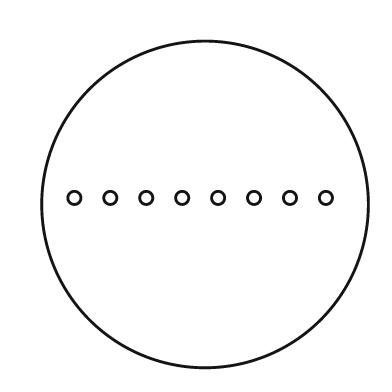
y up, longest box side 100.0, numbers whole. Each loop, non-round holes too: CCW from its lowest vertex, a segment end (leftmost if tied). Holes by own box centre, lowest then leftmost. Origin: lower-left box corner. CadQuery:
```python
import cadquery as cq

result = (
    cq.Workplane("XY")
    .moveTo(50.0, 50.0)
    .circle(50.0)
    .moveTo(10.0, 52.0)
    .circle(2.0)
    .moveTo(21.0, 52.0)
    .circle(2.0)
    .moveTo(32.0, 52.0)
    .circle(2.0)
    .moveTo(43.0, 52.0)
    .circle(2.0)
    .moveTo(54.0, 52.0)
    .circle(2.0)
    .moveTo(65.0, 52.0)
    .circle(2.0)
    .moveTo(76.0, 52.0)
    .circle(2.0)
    .moveTo(87.0, 52.0)
    .circle(2.0)
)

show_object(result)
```